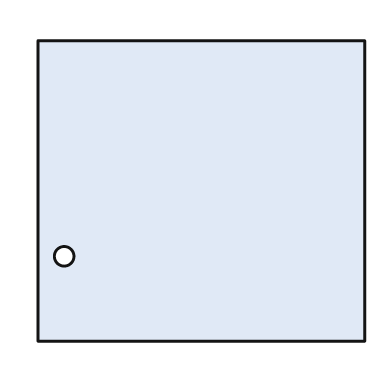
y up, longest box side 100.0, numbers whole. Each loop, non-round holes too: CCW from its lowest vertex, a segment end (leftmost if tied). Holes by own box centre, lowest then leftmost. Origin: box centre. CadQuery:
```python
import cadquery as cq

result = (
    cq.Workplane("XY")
    .moveTo(-50.0, -46.0)
    .lineTo(50.0, -46.0)
    .lineTo(50.0, 46.0)
    .lineTo(-50.0, 46.0)
    .close()
    .moveTo(-42.0, -20.0)
    .circle(3.0)
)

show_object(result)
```